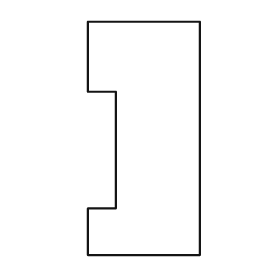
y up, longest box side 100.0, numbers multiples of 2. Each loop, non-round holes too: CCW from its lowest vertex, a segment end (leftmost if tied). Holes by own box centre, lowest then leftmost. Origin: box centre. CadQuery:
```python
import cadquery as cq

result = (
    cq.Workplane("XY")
    .moveTo(-24.0, -50.0)
    .lineTo(24.0, -50.0)
    .lineTo(24.0, 50.0)
    .lineTo(-24.0, 50.0)
    .lineTo(-24.0, 20.0)
    .lineTo(-12.0, 20.0)
    .lineTo(-12.0, -30.0)
    .lineTo(-24.0, -30.0)
    .close()
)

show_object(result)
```